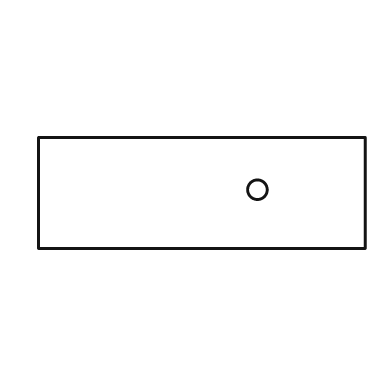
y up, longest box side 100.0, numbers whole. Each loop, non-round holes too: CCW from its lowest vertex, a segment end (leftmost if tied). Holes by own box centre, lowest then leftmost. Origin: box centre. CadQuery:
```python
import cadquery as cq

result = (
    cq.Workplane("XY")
    .moveTo(-50.0, -17.0)
    .lineTo(50.0, -17.0)
    .lineTo(50.0, 17.0)
    .lineTo(-50.0, 17.0)
    .close()
    .moveTo(17.0, 1.0)
    .circle(3.0)
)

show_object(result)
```